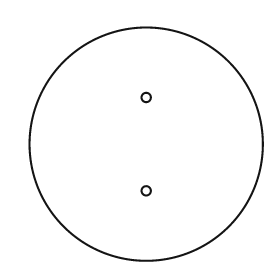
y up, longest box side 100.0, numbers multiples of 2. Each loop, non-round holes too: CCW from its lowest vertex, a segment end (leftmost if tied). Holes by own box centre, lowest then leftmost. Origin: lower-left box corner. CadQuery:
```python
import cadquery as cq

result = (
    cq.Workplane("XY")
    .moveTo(50.0, 50.0)
    .circle(50.0)
    .moveTo(50.0, 30.0)
    .circle(2.0)
    .moveTo(50.0, 70.0)
    .circle(2.0)
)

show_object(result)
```